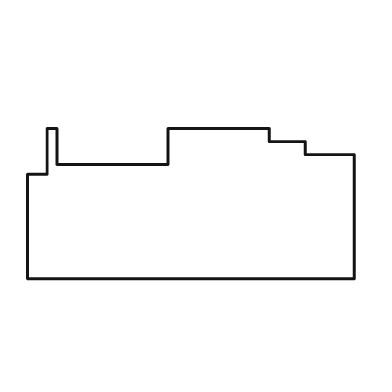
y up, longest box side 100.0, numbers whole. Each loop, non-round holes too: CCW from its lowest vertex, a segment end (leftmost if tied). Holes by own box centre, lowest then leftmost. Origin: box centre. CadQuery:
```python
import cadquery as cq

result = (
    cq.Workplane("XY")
    .moveTo(-50.0, -23.0)
    .lineTo(50.0, -23.0)
    .lineTo(50.0, 15.0)
    .lineTo(35.0, 15.0)
    .lineTo(35.0, 19.0)
    .lineTo(24.0, 19.0)
    .lineTo(24.0, 23.0)
    .lineTo(-7.0, 23.0)
    .lineTo(-7.0, 12.0)
    .lineTo(-41.0, 12.0)
    .lineTo(-41.0, 23.0)
    .lineTo(-44.0, 23.0)
    .lineTo(-44.0, 9.0)
    .lineTo(-50.0, 9.0)
    .close()
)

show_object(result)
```